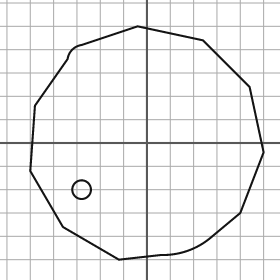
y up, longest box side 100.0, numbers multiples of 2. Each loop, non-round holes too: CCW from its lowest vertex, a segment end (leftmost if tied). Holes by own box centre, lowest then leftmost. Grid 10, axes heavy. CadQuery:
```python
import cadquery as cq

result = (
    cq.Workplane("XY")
    .moveTo(-12.0, -50.0)
    .lineTo(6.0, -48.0)
    .threePointArc((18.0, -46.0), (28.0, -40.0))
    .lineTo(40.0, -30.0)
    .lineTo(50.0, -4.0)
    .lineTo(44.0, 24.0)
    .lineTo(24.0, 44.0)
    .lineTo(-4.0, 50.0)
    .lineTo(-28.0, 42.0)
    .threePointArc((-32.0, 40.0), (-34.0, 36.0))
    .lineTo(-48.0, 16.0)
    .lineTo(-50.0, -12.0)
    .lineTo(-36.0, -36.0)
    .close()
    .moveTo(-28.0, -20.0)
    .circle(4.0)
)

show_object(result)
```